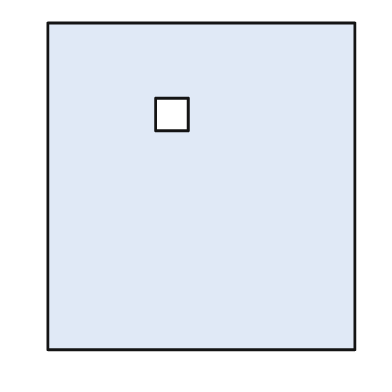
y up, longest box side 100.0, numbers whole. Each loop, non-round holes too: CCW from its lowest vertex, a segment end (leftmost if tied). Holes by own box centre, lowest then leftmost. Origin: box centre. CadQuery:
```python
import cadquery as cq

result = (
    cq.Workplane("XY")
    .moveTo(-47.0, -50.0)
    .lineTo(47.0, -50.0)
    .lineTo(47.0, 50.0)
    .lineTo(-47.0, 50.0)
    .close()
    .moveTo(-14.0, 17.0)
    .lineTo(-4.0, 17.0)
    .lineTo(-4.0, 27.0)
    .lineTo(-14.0, 27.0)
    .close()
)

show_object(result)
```